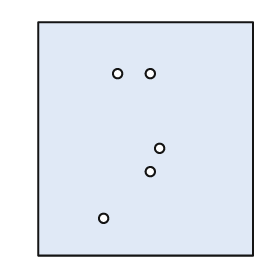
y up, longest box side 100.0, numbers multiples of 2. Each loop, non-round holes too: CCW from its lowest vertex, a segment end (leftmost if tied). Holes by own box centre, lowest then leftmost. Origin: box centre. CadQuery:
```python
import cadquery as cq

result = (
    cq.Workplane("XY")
    .moveTo(-46.0, -50.0)
    .lineTo(46.0, -50.0)
    .lineTo(46.0, 50.0)
    .lineTo(-46.0, 50.0)
    .close()
    .moveTo(-18.0, -34.0)
    .circle(2.0)
    .moveTo(2.0, -14.0)
    .circle(2.0)
    .moveTo(6.0, -4.0)
    .circle(2.0)
    .moveTo(-12.0, 28.0)
    .circle(2.0)
    .moveTo(2.0, 28.0)
    .circle(2.0)
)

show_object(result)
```